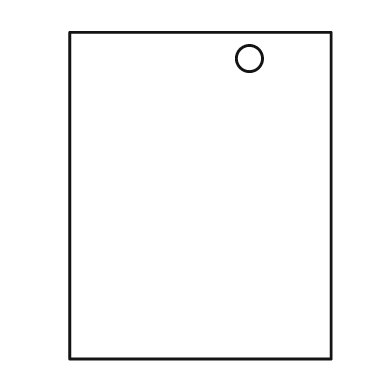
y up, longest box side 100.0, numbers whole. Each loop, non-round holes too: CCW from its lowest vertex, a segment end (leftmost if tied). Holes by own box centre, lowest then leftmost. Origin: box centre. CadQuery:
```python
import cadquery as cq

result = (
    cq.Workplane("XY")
    .moveTo(-40.0, -50.0)
    .lineTo(40.0, -50.0)
    .lineTo(40.0, 50.0)
    .lineTo(-40.0, 50.0)
    .close()
    .moveTo(15.0, 42.0)
    .circle(4.0)
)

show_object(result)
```